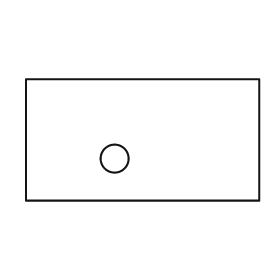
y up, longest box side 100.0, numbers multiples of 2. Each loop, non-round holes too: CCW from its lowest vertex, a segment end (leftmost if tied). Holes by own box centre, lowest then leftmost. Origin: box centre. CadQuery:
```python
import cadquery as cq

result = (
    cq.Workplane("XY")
    .moveTo(-50.0, -26.0)
    .lineTo(50.0, -26.0)
    .lineTo(50.0, 26.0)
    .lineTo(-50.0, 26.0)
    .close()
    .moveTo(-12.0, -8.0)
    .circle(6.0)
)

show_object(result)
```